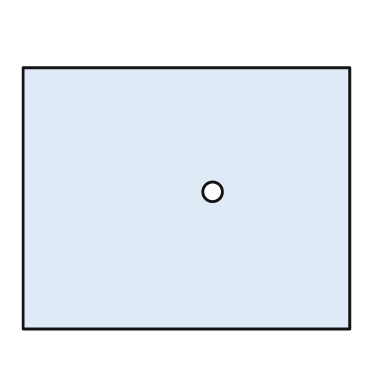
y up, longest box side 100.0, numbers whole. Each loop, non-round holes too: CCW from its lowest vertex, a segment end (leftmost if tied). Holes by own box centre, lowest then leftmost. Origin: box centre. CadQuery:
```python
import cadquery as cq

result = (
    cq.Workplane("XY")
    .moveTo(-50.0, -40.0)
    .lineTo(50.0, -40.0)
    .lineTo(50.0, 40.0)
    .lineTo(-50.0, 40.0)
    .close()
    .moveTo(8.0, 2.0)
    .circle(3.0)
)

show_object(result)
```